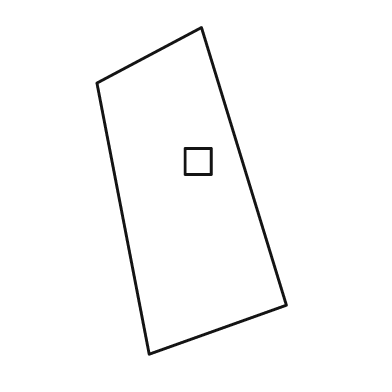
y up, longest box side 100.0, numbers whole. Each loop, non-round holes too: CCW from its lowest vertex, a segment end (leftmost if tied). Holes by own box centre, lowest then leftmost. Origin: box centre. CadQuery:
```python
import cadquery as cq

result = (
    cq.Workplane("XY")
    .moveTo(-13.0, -50.0)
    .lineTo(29.0, -35.0)
    .lineTo(3.0, 50.0)
    .lineTo(-29.0, 33.0)
    .close()
    .moveTo(-2.0, 5.0)
    .lineTo(6.0, 5.0)
    .lineTo(6.0, 13.0)
    .lineTo(-2.0, 13.0)
    .close()
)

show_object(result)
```